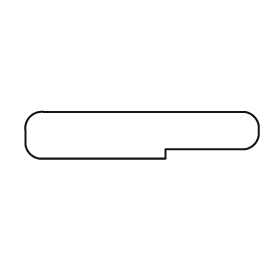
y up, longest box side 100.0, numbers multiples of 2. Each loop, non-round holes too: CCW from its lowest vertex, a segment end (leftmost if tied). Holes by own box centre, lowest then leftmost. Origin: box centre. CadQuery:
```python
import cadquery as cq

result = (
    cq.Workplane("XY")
    .moveTo(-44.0, -10.0)
    .lineTo(10.0, -10.0)
    .lineTo(10.0, -6.0)
    .lineTo(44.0, -6.0)
    .threePointArc((48.0, -4.0), (50.0, 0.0))
    .lineTo(50.0, 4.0)
    .threePointArc((48.0, 8.0), (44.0, 10.0))
    .lineTo(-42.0, 10.0)
    .threePointArc((-48.0, 8.0), (-50.0, 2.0))
    .lineTo(-50.0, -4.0)
    .threePointArc((-48.0, -8.0), (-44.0, -10.0))
    .close()
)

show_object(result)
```